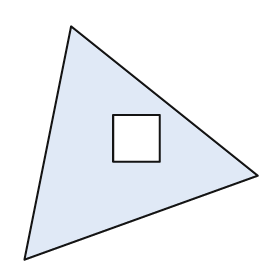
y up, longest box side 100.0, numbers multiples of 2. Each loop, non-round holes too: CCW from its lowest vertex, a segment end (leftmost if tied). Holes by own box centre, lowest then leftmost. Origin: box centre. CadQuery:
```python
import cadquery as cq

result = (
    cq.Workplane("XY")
    .moveTo(-50.0, -50.0)
    .lineTo(50.0, -14.0)
    .lineTo(-30.0, 50.0)
    .close()
    .moveTo(-12.0, -8.0)
    .lineTo(8.0, -8.0)
    .lineTo(8.0, 12.0)
    .lineTo(-12.0, 12.0)
    .close()
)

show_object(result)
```